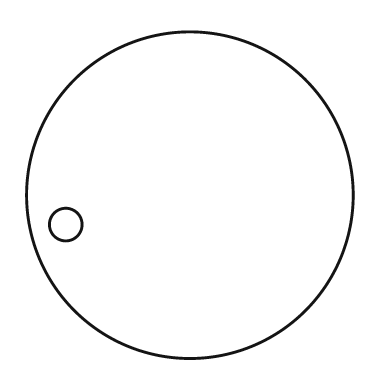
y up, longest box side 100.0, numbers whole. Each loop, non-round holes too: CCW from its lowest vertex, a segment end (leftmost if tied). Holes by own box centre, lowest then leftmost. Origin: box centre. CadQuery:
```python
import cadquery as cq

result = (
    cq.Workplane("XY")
    .moveTo(0.0, 0.0)
    .circle(50.0)
    .moveTo(-38.0, -9.0)
    .circle(5.0)
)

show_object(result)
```